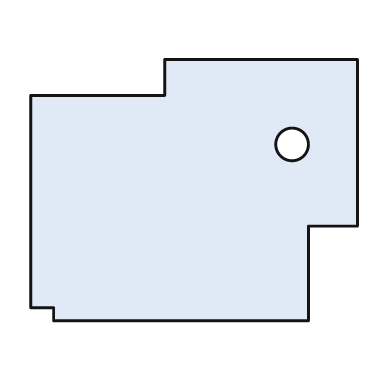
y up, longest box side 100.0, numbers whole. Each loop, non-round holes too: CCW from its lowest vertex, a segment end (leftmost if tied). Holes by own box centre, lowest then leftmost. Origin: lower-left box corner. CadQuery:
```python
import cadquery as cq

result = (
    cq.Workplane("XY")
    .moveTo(7.0, 0.0)
    .lineTo(85.0, 0.0)
    .lineTo(85.0, 29.0)
    .lineTo(100.0, 29.0)
    .lineTo(100.0, 80.0)
    .lineTo(41.0, 80.0)
    .lineTo(41.0, 69.0)
    .lineTo(0.0, 69.0)
    .lineTo(0.0, 4.0)
    .lineTo(7.0, 4.0)
    .close()
    .moveTo(80.0, 54.0)
    .circle(5.0)
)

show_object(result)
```